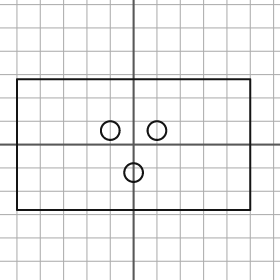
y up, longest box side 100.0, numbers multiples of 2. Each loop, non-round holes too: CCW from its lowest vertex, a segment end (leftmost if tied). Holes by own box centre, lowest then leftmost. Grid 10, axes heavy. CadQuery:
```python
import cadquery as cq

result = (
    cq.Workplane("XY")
    .moveTo(-50.0, -28.0)
    .lineTo(50.0, -28.0)
    .lineTo(50.0, 28.0)
    .lineTo(-50.0, 28.0)
    .close()
    .moveTo(0.0, -12.0)
    .circle(4.0)
    .moveTo(-10.0, 6.0)
    .circle(4.0)
    .moveTo(10.0, 6.0)
    .circle(4.0)
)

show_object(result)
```